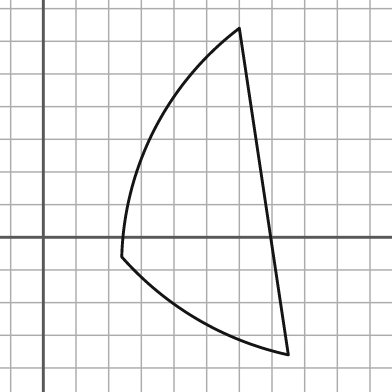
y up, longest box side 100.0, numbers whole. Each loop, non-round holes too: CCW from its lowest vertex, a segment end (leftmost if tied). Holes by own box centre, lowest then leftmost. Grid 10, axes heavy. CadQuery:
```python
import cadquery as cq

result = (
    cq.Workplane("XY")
    .moveTo(75.0, -36.0)
    .lineTo(60.0, 64.0)
    .threePointArc((34.0, 33.0), (24.0, -6.0))
    .threePointArc((47.0, -25.0), (75.0, -36.0))
    .close()
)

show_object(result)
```